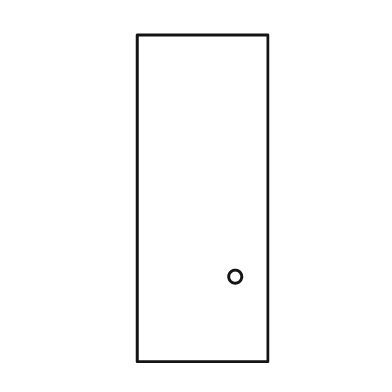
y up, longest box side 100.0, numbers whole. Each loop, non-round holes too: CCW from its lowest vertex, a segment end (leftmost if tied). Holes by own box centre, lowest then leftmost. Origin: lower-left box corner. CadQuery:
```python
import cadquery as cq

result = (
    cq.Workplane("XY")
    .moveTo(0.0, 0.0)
    .lineTo(40.0, 0.0)
    .lineTo(40.0, 100.0)
    .lineTo(0.0, 100.0)
    .close()
    .moveTo(30.0, 26.0)
    .circle(2.0)
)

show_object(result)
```